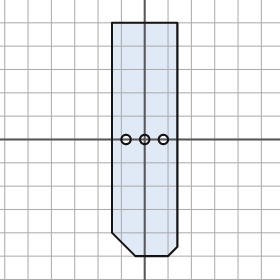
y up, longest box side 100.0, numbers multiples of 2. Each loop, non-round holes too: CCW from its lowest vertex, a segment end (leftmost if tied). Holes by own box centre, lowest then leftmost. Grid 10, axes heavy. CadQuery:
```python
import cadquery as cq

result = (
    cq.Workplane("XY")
    .moveTo(-4.0, -50.0)
    .lineTo(10.0, -50.0)
    .lineTo(14.0, -46.0)
    .lineTo(14.0, 50.0)
    .lineTo(-14.0, 50.0)
    .lineTo(-14.0, -40.0)
    .close()
    .moveTo(-8.0, 0.0)
    .circle(2.0)
    .moveTo(0.0, 0.0)
    .circle(2.0)
    .moveTo(8.0, 0.0)
    .circle(2.0)
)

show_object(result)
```